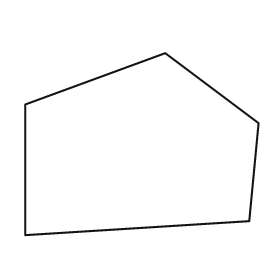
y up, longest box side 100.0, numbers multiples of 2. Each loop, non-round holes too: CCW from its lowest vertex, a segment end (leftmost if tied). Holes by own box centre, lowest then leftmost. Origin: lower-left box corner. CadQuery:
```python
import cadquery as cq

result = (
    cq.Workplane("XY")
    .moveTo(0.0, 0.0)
    .lineTo(96.0, 6.0)
    .lineTo(100.0, 48.0)
    .lineTo(60.0, 78.0)
    .lineTo(0.0, 56.0)
    .close()
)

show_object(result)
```